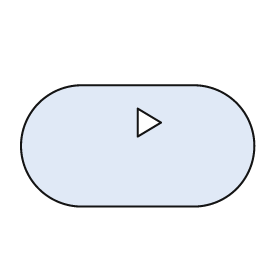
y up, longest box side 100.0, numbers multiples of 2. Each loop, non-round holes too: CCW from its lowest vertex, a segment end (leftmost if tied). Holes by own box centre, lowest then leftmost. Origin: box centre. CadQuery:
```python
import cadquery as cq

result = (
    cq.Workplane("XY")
    .moveTo(-24.0, -26.0)
    .lineTo(24.0, -26.0)
    .threePointArc((50.0, 0.0), (24.0, 26.0))
    .lineTo(-24.0, 26.0)
    .threePointArc((-50.0, 0.0), (-24.0, -26.0))
    .close()
    .moveTo(0.0, 4.0)
    .lineTo(10.0, 10.0)
    .lineTo(0.0, 16.0)
    .close()
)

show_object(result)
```